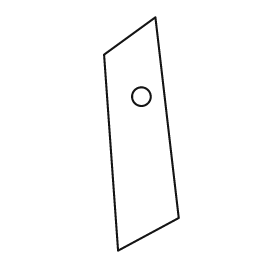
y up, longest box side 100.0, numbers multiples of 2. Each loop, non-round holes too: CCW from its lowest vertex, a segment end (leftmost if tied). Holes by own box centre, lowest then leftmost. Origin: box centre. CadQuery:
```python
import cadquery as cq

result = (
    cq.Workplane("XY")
    .moveTo(-10.0, -50.0)
    .lineTo(16.0, -36.0)
    .lineTo(6.0, 50.0)
    .lineTo(-16.0, 34.0)
    .close()
    .moveTo(0.0, 16.0)
    .circle(4.0)
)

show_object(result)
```